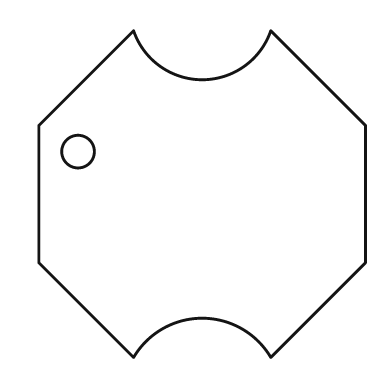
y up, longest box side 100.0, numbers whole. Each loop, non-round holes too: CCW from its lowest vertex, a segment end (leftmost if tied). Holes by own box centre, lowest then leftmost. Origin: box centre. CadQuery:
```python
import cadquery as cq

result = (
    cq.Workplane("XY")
    .moveTo(-21.0, -50.0)
    .threePointArc((0.0, -38.0), (21.0, -50.0))
    .lineTo(50.0, -21.0)
    .lineTo(50.0, 21.0)
    .lineTo(21.0, 50.0)
    .threePointArc((0.0, 35.0), (-21.0, 50.0))
    .lineTo(-50.0, 21.0)
    .lineTo(-50.0, -21.0)
    .close()
    .moveTo(-38.0, 13.0)
    .circle(5.0)
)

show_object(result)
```